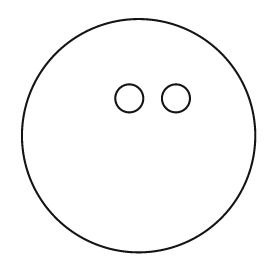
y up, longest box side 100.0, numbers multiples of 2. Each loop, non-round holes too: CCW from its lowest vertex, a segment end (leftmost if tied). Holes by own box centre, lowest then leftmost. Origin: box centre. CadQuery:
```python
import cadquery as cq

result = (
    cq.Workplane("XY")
    .moveTo(0.0, 0.0)
    .circle(50.0)
    .moveTo(-4.0, 16.0)
    .circle(6.0)
    .moveTo(16.0, 16.0)
    .circle(6.0)
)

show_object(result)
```